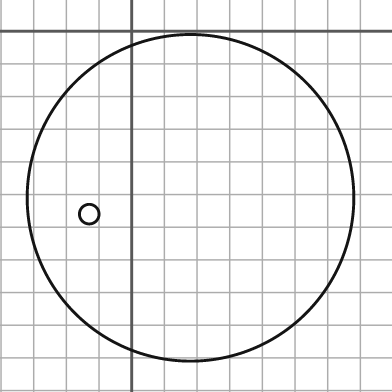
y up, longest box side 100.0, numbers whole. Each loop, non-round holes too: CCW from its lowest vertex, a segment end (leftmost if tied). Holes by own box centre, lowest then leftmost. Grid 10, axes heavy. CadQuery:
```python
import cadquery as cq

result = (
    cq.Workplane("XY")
    .moveTo(18.0, -51.0)
    .circle(50.0)
    .moveTo(-13.0, -56.0)
    .circle(3.0)
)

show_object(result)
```